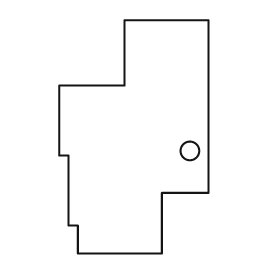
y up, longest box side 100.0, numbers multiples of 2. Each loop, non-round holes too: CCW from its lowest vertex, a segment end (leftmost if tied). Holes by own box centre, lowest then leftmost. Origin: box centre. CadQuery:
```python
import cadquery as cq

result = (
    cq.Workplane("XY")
    .moveTo(-24.0, -50.0)
    .lineTo(12.0, -50.0)
    .lineTo(12.0, -24.0)
    .lineTo(32.0, -24.0)
    .lineTo(32.0, 50.0)
    .lineTo(-4.0, 50.0)
    .lineTo(-4.0, 22.0)
    .lineTo(-32.0, 22.0)
    .lineTo(-32.0, -8.0)
    .lineTo(-28.0, -8.0)
    .lineTo(-28.0, -38.0)
    .lineTo(-24.0, -38.0)
    .close()
    .moveTo(24.0, -6.0)
    .circle(4.0)
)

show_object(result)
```